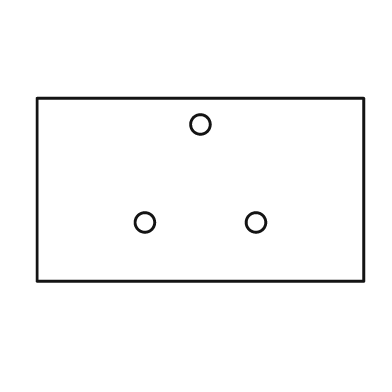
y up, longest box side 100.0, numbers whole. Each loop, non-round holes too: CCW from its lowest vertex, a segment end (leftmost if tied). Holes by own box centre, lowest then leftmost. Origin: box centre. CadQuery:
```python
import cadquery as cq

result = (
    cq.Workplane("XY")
    .moveTo(-50.0, -28.0)
    .lineTo(50.0, -28.0)
    .lineTo(50.0, 28.0)
    .lineTo(-50.0, 28.0)
    .close()
    .moveTo(-17.0, -10.0)
    .circle(3.0)
    .moveTo(17.0, -10.0)
    .circle(3.0)
    .moveTo(0.0, 20.0)
    .circle(3.0)
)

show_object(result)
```